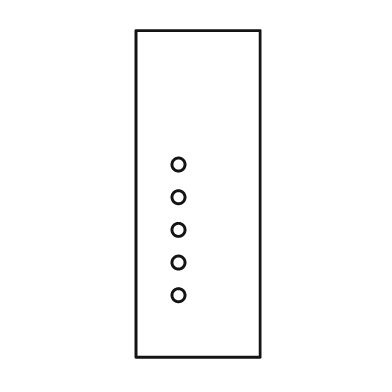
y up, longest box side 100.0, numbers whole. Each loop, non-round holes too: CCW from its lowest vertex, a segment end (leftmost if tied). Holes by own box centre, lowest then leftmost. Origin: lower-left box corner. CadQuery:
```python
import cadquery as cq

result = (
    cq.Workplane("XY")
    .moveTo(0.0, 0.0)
    .lineTo(38.0, 0.0)
    .lineTo(38.0, 100.0)
    .lineTo(0.0, 100.0)
    .close()
    .moveTo(13.0, 19.0)
    .circle(2.0)
    .moveTo(13.0, 29.0)
    .circle(2.0)
    .moveTo(13.0, 39.0)
    .circle(2.0)
    .moveTo(13.0, 49.0)
    .circle(2.0)
    .moveTo(13.0, 59.0)
    .circle(2.0)
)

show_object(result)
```